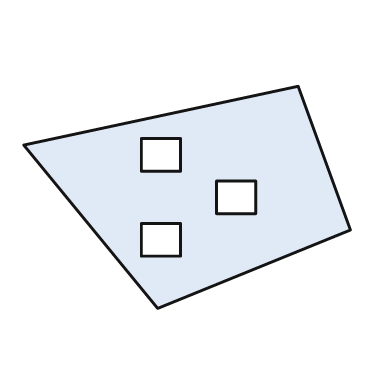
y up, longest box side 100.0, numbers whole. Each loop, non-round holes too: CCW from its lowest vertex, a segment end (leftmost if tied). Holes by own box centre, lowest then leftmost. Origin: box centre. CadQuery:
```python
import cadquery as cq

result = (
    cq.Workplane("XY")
    .moveTo(-9.0, -34.0)
    .lineTo(50.0, -10.0)
    .lineTo(34.0, 34.0)
    .lineTo(-50.0, 16.0)
    .close()
    .moveTo(-14.0, -18.0)
    .lineTo(-2.0, -18.0)
    .lineTo(-2.0, -8.0)
    .lineTo(-14.0, -8.0)
    .close()
    .moveTo(9.0, -5.0)
    .lineTo(21.0, -5.0)
    .lineTo(21.0, 5.0)
    .lineTo(9.0, 5.0)
    .close()
    .moveTo(-14.0, 8.0)
    .lineTo(-2.0, 8.0)
    .lineTo(-2.0, 18.0)
    .lineTo(-14.0, 18.0)
    .close()
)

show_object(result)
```